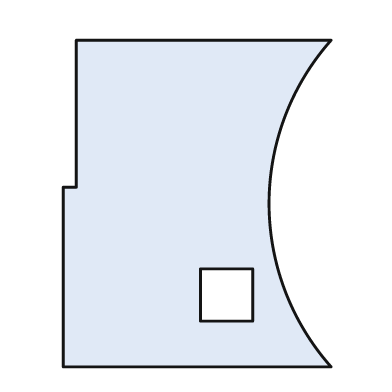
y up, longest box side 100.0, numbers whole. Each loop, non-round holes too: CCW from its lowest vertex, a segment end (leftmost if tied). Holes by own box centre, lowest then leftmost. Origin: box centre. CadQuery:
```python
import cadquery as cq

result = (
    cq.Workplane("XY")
    .moveTo(-41.0, -50.0)
    .lineTo(41.0, -50.0)
    .threePointArc((22.0, 0.0), (41.0, 50.0))
    .lineTo(-37.0, 50.0)
    .lineTo(-37.0, 5.0)
    .lineTo(-41.0, 5.0)
    .close()
    .moveTo(1.0, -36.0)
    .lineTo(17.0, -36.0)
    .lineTo(17.0, -20.0)
    .lineTo(1.0, -20.0)
    .close()
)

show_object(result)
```